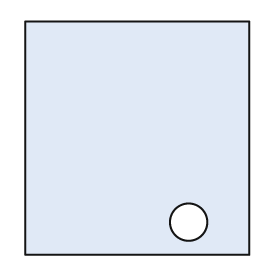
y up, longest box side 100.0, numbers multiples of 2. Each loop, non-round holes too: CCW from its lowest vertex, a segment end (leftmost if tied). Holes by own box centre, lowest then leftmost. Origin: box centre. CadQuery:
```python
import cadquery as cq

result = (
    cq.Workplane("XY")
    .moveTo(-48.0, -50.0)
    .lineTo(48.0, -50.0)
    .lineTo(48.0, 50.0)
    .lineTo(-48.0, 50.0)
    .close()
    .moveTo(22.0, -36.0)
    .circle(8.0)
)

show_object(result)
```